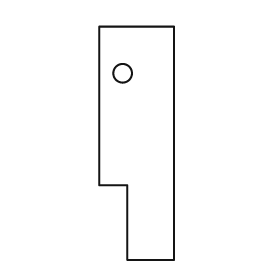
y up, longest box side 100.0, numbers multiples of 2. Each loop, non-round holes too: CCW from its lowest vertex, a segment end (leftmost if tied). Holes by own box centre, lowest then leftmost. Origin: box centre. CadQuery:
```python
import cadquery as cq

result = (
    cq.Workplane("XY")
    .moveTo(-4.0, -50.0)
    .lineTo(16.0, -50.0)
    .lineTo(16.0, 50.0)
    .lineTo(-16.0, 50.0)
    .lineTo(-16.0, -18.0)
    .lineTo(-4.0, -18.0)
    .close()
    .moveTo(-6.0, 30.0)
    .circle(4.0)
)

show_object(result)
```